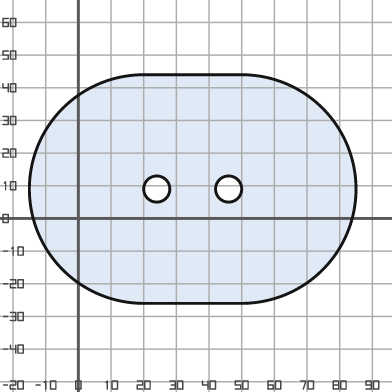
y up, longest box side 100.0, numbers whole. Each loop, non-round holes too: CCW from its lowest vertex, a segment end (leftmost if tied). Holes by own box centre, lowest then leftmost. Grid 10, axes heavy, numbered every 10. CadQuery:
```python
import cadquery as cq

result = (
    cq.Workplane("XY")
    .moveTo(20.0, -26.0)
    .lineTo(50.0, -26.0)
    .threePointArc((85.0, 9.0), (50.0, 44.0))
    .lineTo(20.0, 44.0)
    .threePointArc((-15.0, 9.0), (20.0, -26.0))
    .close()
    .moveTo(24.0, 9.0)
    .circle(4.0)
    .moveTo(46.0, 9.0)
    .circle(4.0)
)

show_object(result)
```